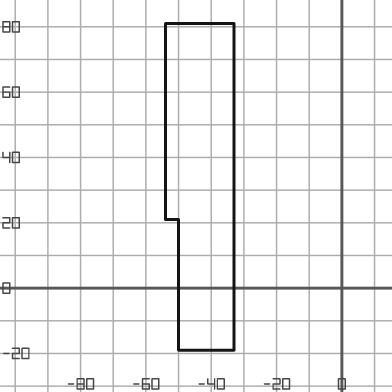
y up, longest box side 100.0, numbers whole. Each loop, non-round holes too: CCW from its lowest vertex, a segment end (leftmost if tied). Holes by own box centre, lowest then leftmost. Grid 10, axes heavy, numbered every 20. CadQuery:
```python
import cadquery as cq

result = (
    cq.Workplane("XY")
    .moveTo(-50.0, -19.0)
    .lineTo(-33.0, -19.0)
    .lineTo(-33.0, 81.0)
    .lineTo(-54.0, 81.0)
    .lineTo(-54.0, 21.0)
    .lineTo(-50.0, 21.0)
    .close()
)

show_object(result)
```